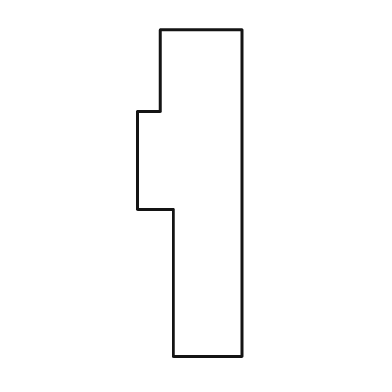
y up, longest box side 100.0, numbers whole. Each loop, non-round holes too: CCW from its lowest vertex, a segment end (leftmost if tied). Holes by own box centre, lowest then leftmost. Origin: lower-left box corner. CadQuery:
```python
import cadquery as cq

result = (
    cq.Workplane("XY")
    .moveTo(11.0, 0.0)
    .lineTo(32.0, 0.0)
    .lineTo(32.0, 100.0)
    .lineTo(7.0, 100.0)
    .lineTo(7.0, 75.0)
    .lineTo(0.0, 75.0)
    .lineTo(0.0, 45.0)
    .lineTo(11.0, 45.0)
    .close()
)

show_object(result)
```